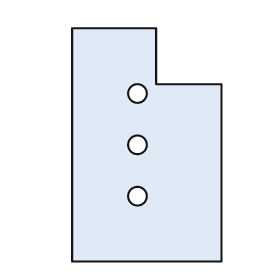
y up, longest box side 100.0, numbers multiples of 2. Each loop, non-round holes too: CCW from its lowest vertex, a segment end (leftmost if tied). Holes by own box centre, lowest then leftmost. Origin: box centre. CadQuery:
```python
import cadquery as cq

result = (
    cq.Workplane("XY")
    .moveTo(-32.0, -50.0)
    .lineTo(32.0, -50.0)
    .lineTo(32.0, 26.0)
    .lineTo(4.0, 26.0)
    .lineTo(4.0, 50.0)
    .lineTo(-32.0, 50.0)
    .close()
    .moveTo(-4.0, -22.0)
    .circle(4.0)
    .moveTo(-4.0, 0.0)
    .circle(4.0)
    .moveTo(-4.0, 22.0)
    .circle(4.0)
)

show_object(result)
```